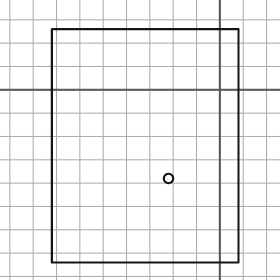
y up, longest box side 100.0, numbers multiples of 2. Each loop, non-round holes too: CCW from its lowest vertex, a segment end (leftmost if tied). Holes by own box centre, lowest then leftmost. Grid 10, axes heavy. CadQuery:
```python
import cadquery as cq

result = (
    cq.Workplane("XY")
    .moveTo(-72.0, -74.0)
    .lineTo(8.0, -74.0)
    .lineTo(8.0, 26.0)
    .lineTo(-72.0, 26.0)
    .close()
    .moveTo(-22.0, -38.0)
    .circle(2.0)
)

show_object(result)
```